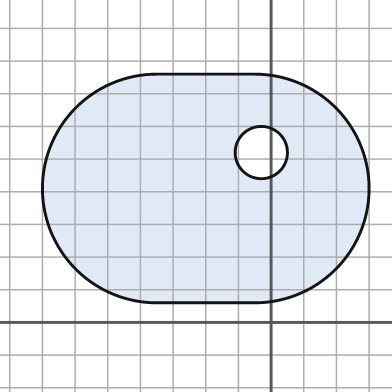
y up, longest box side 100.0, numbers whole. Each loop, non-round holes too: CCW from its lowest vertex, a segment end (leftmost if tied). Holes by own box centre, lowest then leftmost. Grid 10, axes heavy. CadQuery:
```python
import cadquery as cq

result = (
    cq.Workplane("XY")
    .moveTo(-35.0, 6.0)
    .lineTo(-5.0, 6.0)
    .threePointArc((30.0, 41.0), (-5.0, 76.0))
    .lineTo(-35.0, 76.0)
    .threePointArc((-70.0, 41.0), (-35.0, 6.0))
    .close()
    .moveTo(-3.0, 52.0)
    .circle(8.0)
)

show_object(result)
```